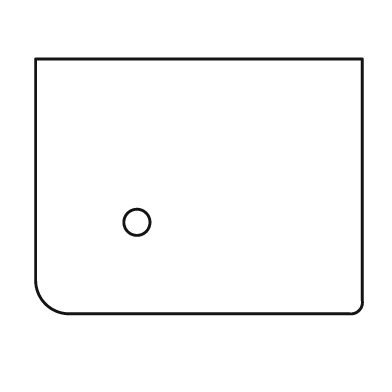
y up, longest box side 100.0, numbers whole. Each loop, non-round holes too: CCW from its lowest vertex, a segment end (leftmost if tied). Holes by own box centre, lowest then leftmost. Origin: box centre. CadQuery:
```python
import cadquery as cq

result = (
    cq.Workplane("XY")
    .moveTo(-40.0, -39.0)
    .lineTo(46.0, -39.0)
    .threePointArc((49.0, -38.0), (50.0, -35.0))
    .lineTo(50.0, 39.0)
    .lineTo(-50.0, 39.0)
    .lineTo(-50.0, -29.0)
    .threePointArc((-47.0, -36.0), (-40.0, -39.0))
    .close()
    .moveTo(-19.0, -11.0)
    .circle(4.0)
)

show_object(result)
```